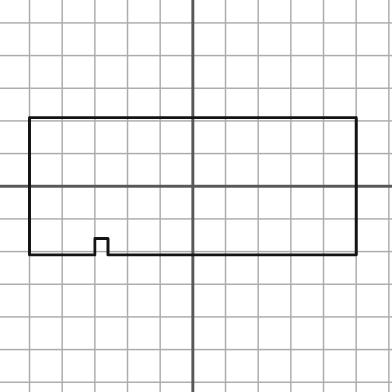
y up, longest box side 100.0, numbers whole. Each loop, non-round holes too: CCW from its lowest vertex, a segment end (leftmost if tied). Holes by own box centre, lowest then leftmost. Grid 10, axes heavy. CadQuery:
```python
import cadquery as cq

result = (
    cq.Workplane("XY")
    .moveTo(-50.0, -21.0)
    .lineTo(-30.0, -21.0)
    .lineTo(-30.0, -16.0)
    .lineTo(-26.0, -16.0)
    .lineTo(-26.0, -21.0)
    .lineTo(50.0, -21.0)
    .lineTo(50.0, 21.0)
    .lineTo(-50.0, 21.0)
    .close()
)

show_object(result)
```